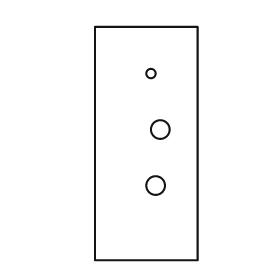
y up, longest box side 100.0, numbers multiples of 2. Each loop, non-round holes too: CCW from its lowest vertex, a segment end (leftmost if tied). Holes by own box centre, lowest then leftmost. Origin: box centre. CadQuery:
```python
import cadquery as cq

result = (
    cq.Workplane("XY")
    .moveTo(-22.0, -50.0)
    .lineTo(22.0, -50.0)
    .lineTo(22.0, 50.0)
    .lineTo(-22.0, 50.0)
    .close()
    .moveTo(4.0, -18.0)
    .circle(4.0)
    .moveTo(6.0, 6.0)
    .circle(4.0)
    .moveTo(2.0, 30.0)
    .circle(2.0)
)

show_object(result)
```